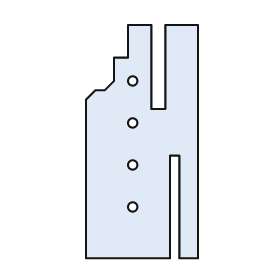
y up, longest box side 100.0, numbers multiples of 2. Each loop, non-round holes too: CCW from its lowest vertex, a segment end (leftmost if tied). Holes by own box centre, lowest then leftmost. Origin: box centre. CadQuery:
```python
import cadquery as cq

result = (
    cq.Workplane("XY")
    .moveTo(-24.0, -50.0)
    .lineTo(12.0, -50.0)
    .lineTo(12.0, -6.0)
    .lineTo(16.0, -6.0)
    .lineTo(16.0, -50.0)
    .lineTo(24.0, -50.0)
    .lineTo(24.0, 50.0)
    .lineTo(10.0, 50.0)
    .lineTo(10.0, 14.0)
    .lineTo(4.0, 14.0)
    .lineTo(4.0, 50.0)
    .lineTo(-6.0, 50.0)
    .lineTo(-6.0, 36.0)
    .lineTo(-12.0, 36.0)
    .lineTo(-12.0, 26.0)
    .lineTo(-16.0, 22.0)
    .lineTo(-20.0, 22.0)
    .lineTo(-24.0, 18.0)
    .close()
    .moveTo(-4.0, -28.0)
    .circle(2.0)
    .moveTo(-4.0, -10.0)
    .circle(2.0)
    .moveTo(-4.0, 8.0)
    .circle(2.0)
    .moveTo(-4.0, 26.0)
    .circle(2.0)
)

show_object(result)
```